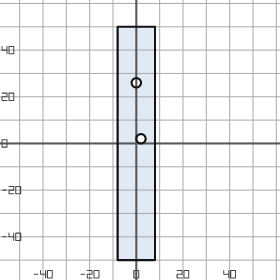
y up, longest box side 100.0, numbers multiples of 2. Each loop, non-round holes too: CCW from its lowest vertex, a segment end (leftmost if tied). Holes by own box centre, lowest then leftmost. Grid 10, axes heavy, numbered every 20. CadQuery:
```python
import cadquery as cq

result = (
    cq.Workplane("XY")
    .moveTo(-8.0, -50.0)
    .lineTo(8.0, -50.0)
    .lineTo(8.0, 50.0)
    .lineTo(-8.0, 50.0)
    .close()
    .moveTo(2.0, 2.0)
    .circle(2.0)
    .moveTo(0.0, 26.0)
    .circle(2.0)
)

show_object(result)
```